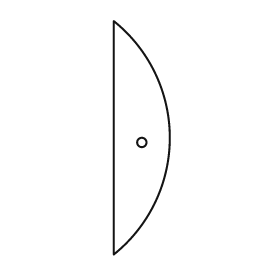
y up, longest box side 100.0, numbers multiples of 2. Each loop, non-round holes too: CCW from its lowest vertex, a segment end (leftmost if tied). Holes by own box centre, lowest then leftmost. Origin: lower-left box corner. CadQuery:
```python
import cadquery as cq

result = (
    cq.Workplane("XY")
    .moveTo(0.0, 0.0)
    .threePointArc((24.0, 50.0), (0.0, 100.0))
    .close()
    .moveTo(12.0, 48.0)
    .circle(2.0)
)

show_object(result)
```